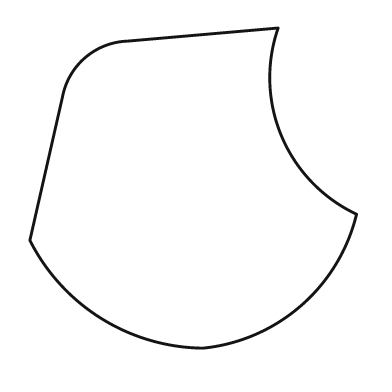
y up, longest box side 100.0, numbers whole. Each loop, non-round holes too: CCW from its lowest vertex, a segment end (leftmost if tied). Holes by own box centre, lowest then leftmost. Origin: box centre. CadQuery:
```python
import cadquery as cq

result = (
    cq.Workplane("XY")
    .moveTo(3.0, -49.0)
    .threePointArc((33.0, -36.0), (50.0, -8.0))
    .threePointArc((27.0, 16.0), (26.0, 49.0))
    .lineTo(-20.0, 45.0)
    .threePointArc((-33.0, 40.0), (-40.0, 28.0))
    .lineTo(-50.0, -16.0)
    .threePointArc((-28.0, -40.0), (3.0, -49.0))
    .close()
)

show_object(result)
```